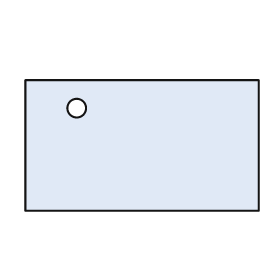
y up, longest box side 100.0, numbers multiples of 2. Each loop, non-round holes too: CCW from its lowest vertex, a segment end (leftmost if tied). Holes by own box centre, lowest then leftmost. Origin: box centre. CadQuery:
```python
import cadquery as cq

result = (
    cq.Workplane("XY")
    .moveTo(-50.0, -28.0)
    .lineTo(50.0, -28.0)
    .lineTo(50.0, 28.0)
    .lineTo(-50.0, 28.0)
    .close()
    .moveTo(-28.0, 16.0)
    .circle(4.0)
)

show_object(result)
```